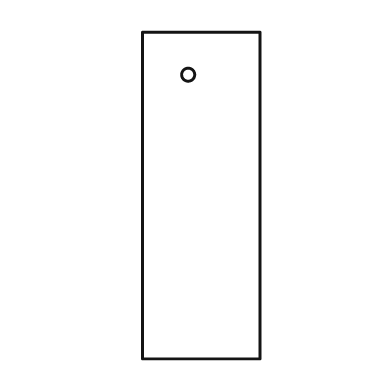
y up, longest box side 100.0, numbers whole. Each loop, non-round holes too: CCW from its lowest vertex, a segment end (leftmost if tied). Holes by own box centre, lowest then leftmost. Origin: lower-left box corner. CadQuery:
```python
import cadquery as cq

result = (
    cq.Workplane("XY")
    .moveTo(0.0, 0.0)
    .lineTo(36.0, 0.0)
    .lineTo(36.0, 100.0)
    .lineTo(0.0, 100.0)
    .close()
    .moveTo(14.0, 87.0)
    .circle(2.0)
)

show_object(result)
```